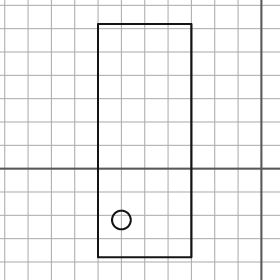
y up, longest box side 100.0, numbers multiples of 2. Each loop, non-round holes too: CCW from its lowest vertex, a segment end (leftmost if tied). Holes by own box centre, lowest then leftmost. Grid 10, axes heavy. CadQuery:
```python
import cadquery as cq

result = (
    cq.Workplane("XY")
    .moveTo(-70.0, -38.0)
    .lineTo(-30.0, -38.0)
    .lineTo(-30.0, 62.0)
    .lineTo(-70.0, 62.0)
    .close()
    .moveTo(-60.0, -22.0)
    .circle(4.0)
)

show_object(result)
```